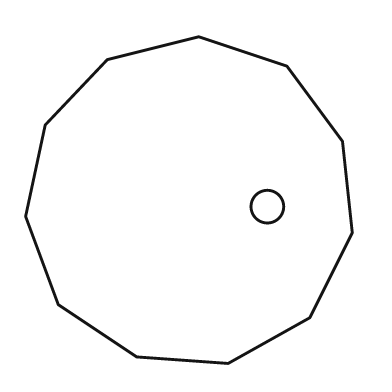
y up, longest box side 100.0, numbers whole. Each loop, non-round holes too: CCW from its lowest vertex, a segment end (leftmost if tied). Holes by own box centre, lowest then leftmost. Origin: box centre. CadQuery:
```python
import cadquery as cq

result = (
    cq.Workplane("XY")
    .moveTo(12.0, -50.0)
    .lineTo(37.0, -36.0)
    .lineTo(50.0, -10.0)
    .lineTo(47.0, 18.0)
    .lineTo(30.0, 41.0)
    .lineTo(3.0, 50.0)
    .lineTo(-25.0, 43.0)
    .lineTo(-44.0, 23.0)
    .lineTo(-50.0, -5.0)
    .lineTo(-40.0, -32.0)
    .lineTo(-16.0, -48.0)
    .close()
    .moveTo(24.0, -2.0)
    .circle(5.0)
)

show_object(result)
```